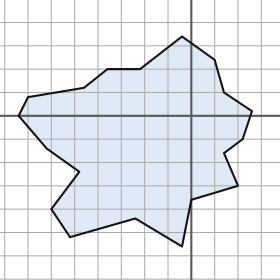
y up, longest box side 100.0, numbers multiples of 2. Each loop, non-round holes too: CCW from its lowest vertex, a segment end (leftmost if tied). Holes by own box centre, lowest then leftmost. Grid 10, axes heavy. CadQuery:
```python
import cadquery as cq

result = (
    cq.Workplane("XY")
    .moveTo(-4.0, -56.0)
    .lineTo(0.0, -36.0)
    .lineTo(20.0, -30.0)
    .lineTo(14.0, -16.0)
    .lineTo(22.0, -10.0)
    .lineTo(26.0, 2.0)
    .lineTo(14.0, 10.0)
    .lineTo(10.0, 24.0)
    .lineTo(-4.0, 34.0)
    .lineTo(-22.0, 20.0)
    .lineTo(-36.0, 20.0)
    .lineTo(-46.0, 12.0)
    .lineTo(-70.0, 8.0)
    .lineTo(-74.0, 0.0)
    .lineTo(-62.0, -14.0)
    .lineTo(-48.0, -24.0)
    .lineTo(-60.0, -40.0)
    .lineTo(-52.0, -52.0)
    .lineTo(-24.0, -44.0)
    .close()
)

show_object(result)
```